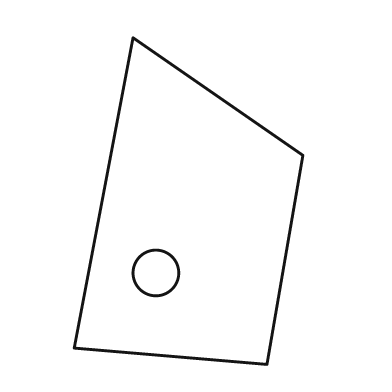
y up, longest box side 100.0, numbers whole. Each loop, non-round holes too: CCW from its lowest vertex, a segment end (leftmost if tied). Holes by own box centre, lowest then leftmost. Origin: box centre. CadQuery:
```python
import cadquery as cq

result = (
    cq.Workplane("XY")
    .moveTo(24.0, -50.0)
    .lineTo(35.0, 14.0)
    .lineTo(-17.0, 50.0)
    .lineTo(-35.0, -45.0)
    .close()
    .moveTo(-10.0, -22.0)
    .circle(7.0)
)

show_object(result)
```